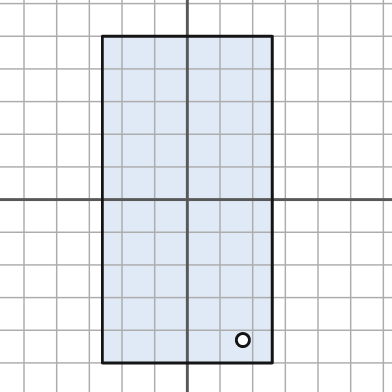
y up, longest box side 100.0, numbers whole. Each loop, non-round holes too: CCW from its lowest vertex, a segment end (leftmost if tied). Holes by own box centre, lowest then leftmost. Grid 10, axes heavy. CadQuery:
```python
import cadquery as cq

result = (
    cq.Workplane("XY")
    .moveTo(-26.0, -50.0)
    .lineTo(26.0, -50.0)
    .lineTo(26.0, 50.0)
    .lineTo(-26.0, 50.0)
    .close()
    .moveTo(17.0, -43.0)
    .circle(2.0)
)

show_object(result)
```